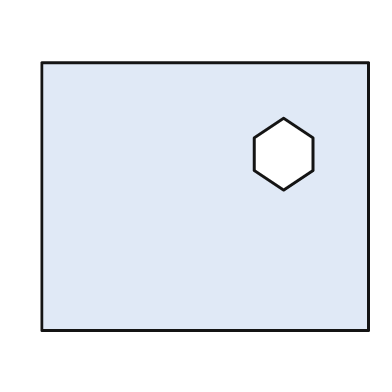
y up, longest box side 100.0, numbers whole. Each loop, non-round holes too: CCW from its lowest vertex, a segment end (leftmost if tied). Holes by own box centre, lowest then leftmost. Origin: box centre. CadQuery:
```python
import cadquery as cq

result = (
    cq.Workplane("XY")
    .moveTo(-50.0, -41.0)
    .lineTo(50.0, -41.0)
    .lineTo(50.0, 41.0)
    .lineTo(-50.0, 41.0)
    .close()
    .moveTo(24.0, 2.0)
    .lineTo(33.0, 8.0)
    .lineTo(33.0, 18.0)
    .lineTo(24.0, 24.0)
    .lineTo(15.0, 18.0)
    .lineTo(15.0, 8.0)
    .close()
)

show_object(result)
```